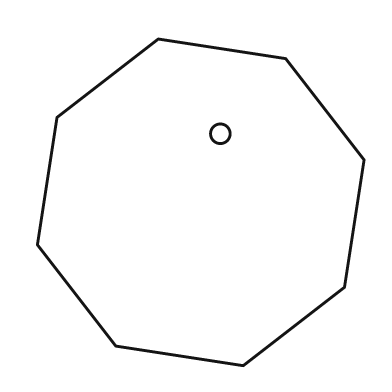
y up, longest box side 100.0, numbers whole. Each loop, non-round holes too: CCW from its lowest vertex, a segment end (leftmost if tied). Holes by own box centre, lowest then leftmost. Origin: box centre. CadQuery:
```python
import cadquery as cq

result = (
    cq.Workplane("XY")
    .moveTo(13.0, -50.0)
    .lineTo(44.0, -26.0)
    .lineTo(50.0, 13.0)
    .lineTo(26.0, 44.0)
    .lineTo(-13.0, 50.0)
    .lineTo(-44.0, 26.0)
    .lineTo(-50.0, -13.0)
    .lineTo(-26.0, -44.0)
    .close()
    .moveTo(6.0, 21.0)
    .circle(3.0)
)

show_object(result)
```